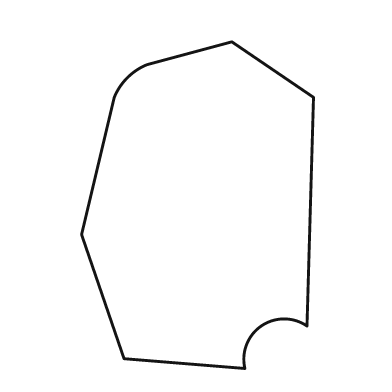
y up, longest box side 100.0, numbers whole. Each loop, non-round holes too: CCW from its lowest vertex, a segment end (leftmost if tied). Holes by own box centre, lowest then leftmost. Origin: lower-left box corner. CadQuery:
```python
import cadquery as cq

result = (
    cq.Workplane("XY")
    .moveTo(50.0, 0.0)
    .threePointArc((55.0, 13.0), (69.0, 13.0))
    .lineTo(71.0, 83.0)
    .lineTo(46.0, 100.0)
    .lineTo(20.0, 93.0)
    .threePointArc((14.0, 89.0), (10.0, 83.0))
    .lineTo(0.0, 41.0)
    .lineTo(13.0, 3.0)
    .close()
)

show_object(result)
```